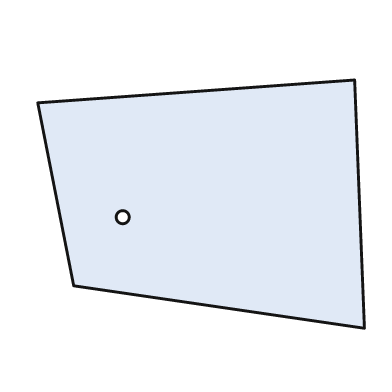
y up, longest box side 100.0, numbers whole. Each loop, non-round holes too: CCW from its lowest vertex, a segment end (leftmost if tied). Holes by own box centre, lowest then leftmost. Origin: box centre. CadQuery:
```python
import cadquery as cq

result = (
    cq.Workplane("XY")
    .moveTo(50.0, -38.0)
    .lineTo(47.0, 38.0)
    .lineTo(-50.0, 31.0)
    .lineTo(-39.0, -25.0)
    .close()
    .moveTo(-24.0, -4.0)
    .circle(2.0)
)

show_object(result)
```